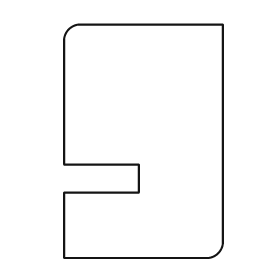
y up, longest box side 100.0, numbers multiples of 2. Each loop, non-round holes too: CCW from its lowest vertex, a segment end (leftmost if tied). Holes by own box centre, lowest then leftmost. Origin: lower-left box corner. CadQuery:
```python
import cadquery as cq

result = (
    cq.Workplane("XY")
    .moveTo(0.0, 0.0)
    .lineTo(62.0, 0.0)
    .threePointArc((66.0, 2.0), (68.0, 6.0))
    .lineTo(68.0, 100.0)
    .lineTo(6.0, 100.0)
    .threePointArc((2.0, 98.0), (0.0, 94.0))
    .lineTo(0.0, 40.0)
    .lineTo(32.0, 40.0)
    .lineTo(32.0, 28.0)
    .lineTo(0.0, 28.0)
    .close()
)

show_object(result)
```